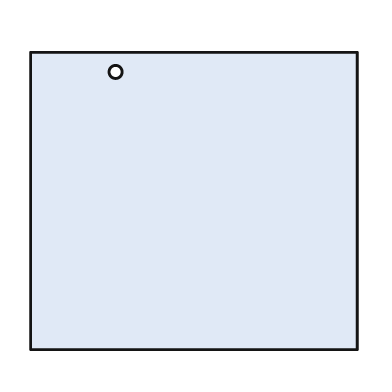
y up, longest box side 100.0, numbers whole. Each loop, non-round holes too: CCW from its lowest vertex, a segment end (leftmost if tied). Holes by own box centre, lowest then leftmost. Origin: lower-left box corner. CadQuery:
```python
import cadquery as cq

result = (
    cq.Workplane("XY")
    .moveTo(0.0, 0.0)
    .lineTo(100.0, 0.0)
    .lineTo(100.0, 91.0)
    .lineTo(0.0, 91.0)
    .close()
    .moveTo(26.0, 85.0)
    .circle(2.0)
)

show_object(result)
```